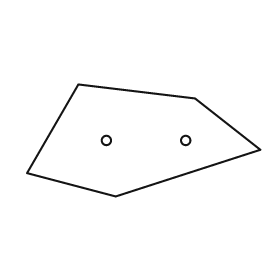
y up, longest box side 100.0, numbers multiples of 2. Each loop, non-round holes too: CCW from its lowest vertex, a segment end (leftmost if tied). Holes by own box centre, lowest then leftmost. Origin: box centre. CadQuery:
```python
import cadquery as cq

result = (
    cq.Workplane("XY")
    .moveTo(-12.0, -24.0)
    .lineTo(50.0, -4.0)
    .lineTo(22.0, 18.0)
    .lineTo(-28.0, 24.0)
    .lineTo(-50.0, -14.0)
    .close()
    .moveTo(-16.0, 0.0)
    .circle(2.0)
    .moveTo(18.0, 0.0)
    .circle(2.0)
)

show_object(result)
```